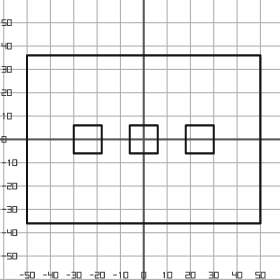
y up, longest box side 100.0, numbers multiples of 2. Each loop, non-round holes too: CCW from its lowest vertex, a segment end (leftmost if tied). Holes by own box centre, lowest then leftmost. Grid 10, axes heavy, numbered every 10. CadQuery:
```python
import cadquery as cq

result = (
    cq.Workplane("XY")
    .moveTo(-50.0, -36.0)
    .lineTo(50.0, -36.0)
    .lineTo(50.0, 36.0)
    .lineTo(-50.0, 36.0)
    .close()
    .moveTo(-30.0, -6.0)
    .lineTo(-18.0, -6.0)
    .lineTo(-18.0, 6.0)
    .lineTo(-30.0, 6.0)
    .close()
    .moveTo(-6.0, -6.0)
    .lineTo(6.0, -6.0)
    .lineTo(6.0, 6.0)
    .lineTo(-6.0, 6.0)
    .close()
    .moveTo(18.0, -6.0)
    .lineTo(30.0, -6.0)
    .lineTo(30.0, 6.0)
    .lineTo(18.0, 6.0)
    .close()
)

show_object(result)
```